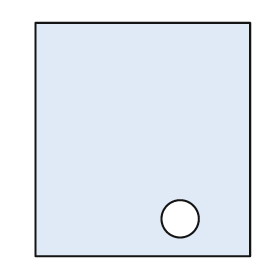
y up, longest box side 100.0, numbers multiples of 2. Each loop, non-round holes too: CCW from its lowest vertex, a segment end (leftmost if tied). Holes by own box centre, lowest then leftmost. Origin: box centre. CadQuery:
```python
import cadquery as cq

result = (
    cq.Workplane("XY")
    .moveTo(-46.0, -50.0)
    .lineTo(46.0, -50.0)
    .lineTo(46.0, 50.0)
    .lineTo(-46.0, 50.0)
    .close()
    .moveTo(16.0, -34.0)
    .circle(8.0)
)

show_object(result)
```